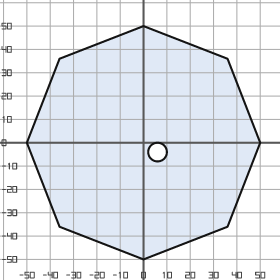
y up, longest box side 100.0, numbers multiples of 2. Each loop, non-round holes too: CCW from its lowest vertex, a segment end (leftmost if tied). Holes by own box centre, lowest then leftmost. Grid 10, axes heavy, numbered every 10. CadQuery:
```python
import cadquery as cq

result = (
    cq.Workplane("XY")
    .moveTo(0.0, -50.0)
    .lineTo(36.0, -36.0)
    .lineTo(50.0, 0.0)
    .lineTo(36.0, 36.0)
    .lineTo(0.0, 50.0)
    .lineTo(-36.0, 36.0)
    .lineTo(-50.0, 0.0)
    .lineTo(-36.0, -36.0)
    .close()
    .moveTo(6.0, -4.0)
    .circle(4.0)
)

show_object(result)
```